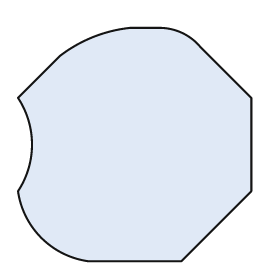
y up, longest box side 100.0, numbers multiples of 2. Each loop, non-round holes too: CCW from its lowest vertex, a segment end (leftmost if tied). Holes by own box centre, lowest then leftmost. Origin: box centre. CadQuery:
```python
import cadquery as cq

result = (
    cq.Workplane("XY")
    .moveTo(-20.0, -50.0)
    .lineTo(20.0, -50.0)
    .lineTo(50.0, -20.0)
    .lineTo(50.0, 20.0)
    .lineTo(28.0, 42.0)
    .threePointArc((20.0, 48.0), (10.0, 50.0))
    .lineTo(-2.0, 50.0)
    .threePointArc((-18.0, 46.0), (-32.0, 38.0))
    .lineTo(-50.0, 20.0)
    .threePointArc((-44.0, 0.0), (-50.0, -20.0))
    .threePointArc((-40.0, -40.0), (-20.0, -50.0))
    .close()
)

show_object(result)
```